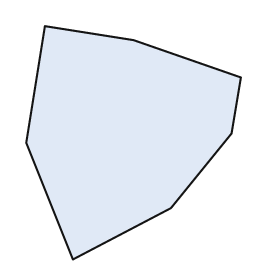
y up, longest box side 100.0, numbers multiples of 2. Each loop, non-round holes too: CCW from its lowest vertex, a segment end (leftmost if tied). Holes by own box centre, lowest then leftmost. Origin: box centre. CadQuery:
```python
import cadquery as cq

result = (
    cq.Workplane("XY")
    .moveTo(-26.0, -50.0)
    .lineTo(16.0, -28.0)
    .lineTo(42.0, 4.0)
    .lineTo(46.0, 28.0)
    .lineTo(0.0, 44.0)
    .lineTo(-38.0, 50.0)
    .lineTo(-46.0, 0.0)
    .close()
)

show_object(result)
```